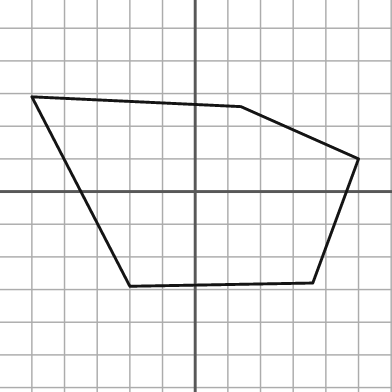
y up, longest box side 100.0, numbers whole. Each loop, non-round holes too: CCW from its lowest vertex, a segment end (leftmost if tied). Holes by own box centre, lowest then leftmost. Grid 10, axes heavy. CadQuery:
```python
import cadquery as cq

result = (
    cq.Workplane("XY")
    .moveTo(-20.0, -29.0)
    .lineTo(36.0, -28.0)
    .lineTo(50.0, 10.0)
    .lineTo(14.0, 26.0)
    .lineTo(-50.0, 29.0)
    .close()
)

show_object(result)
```